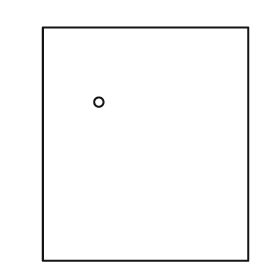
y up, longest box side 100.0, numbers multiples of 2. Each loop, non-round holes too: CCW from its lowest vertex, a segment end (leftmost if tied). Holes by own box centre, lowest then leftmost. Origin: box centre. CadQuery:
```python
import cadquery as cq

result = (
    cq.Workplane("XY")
    .moveTo(-44.0, -50.0)
    .lineTo(44.0, -50.0)
    .lineTo(44.0, 50.0)
    .lineTo(-44.0, 50.0)
    .close()
    .moveTo(-20.0, 18.0)
    .circle(2.0)
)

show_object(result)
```